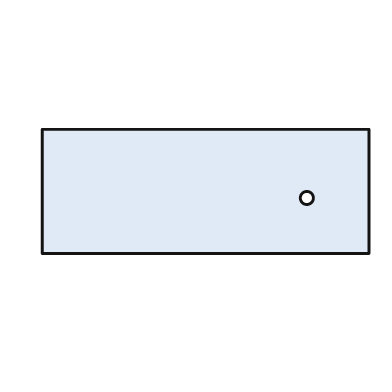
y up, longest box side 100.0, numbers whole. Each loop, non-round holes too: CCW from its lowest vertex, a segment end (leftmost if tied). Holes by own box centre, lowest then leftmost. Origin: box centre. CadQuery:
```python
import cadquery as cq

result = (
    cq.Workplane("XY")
    .moveTo(-50.0, -19.0)
    .lineTo(50.0, -19.0)
    .lineTo(50.0, 19.0)
    .lineTo(-50.0, 19.0)
    .close()
    .moveTo(31.0, -2.0)
    .circle(2.0)
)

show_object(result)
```